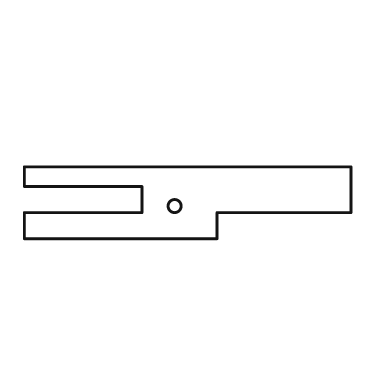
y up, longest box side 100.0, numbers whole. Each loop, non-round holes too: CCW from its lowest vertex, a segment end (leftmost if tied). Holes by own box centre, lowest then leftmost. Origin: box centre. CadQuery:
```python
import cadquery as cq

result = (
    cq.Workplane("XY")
    .moveTo(-50.0, -11.0)
    .lineTo(9.0, -11.0)
    .lineTo(9.0, -3.0)
    .lineTo(50.0, -3.0)
    .lineTo(50.0, 11.0)
    .lineTo(-50.0, 11.0)
    .lineTo(-50.0, 5.0)
    .lineTo(-14.0, 5.0)
    .lineTo(-14.0, -3.0)
    .lineTo(-50.0, -3.0)
    .close()
    .moveTo(-4.0, -1.0)
    .circle(2.0)
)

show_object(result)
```